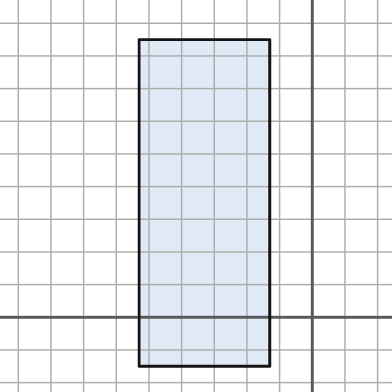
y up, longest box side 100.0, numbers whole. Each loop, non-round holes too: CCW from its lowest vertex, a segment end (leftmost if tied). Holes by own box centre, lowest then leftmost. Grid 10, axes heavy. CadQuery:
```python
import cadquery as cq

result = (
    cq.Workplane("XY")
    .moveTo(-53.0, -15.0)
    .lineTo(-13.0, -15.0)
    .lineTo(-13.0, 85.0)
    .lineTo(-53.0, 85.0)
    .close()
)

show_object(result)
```